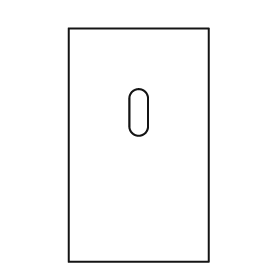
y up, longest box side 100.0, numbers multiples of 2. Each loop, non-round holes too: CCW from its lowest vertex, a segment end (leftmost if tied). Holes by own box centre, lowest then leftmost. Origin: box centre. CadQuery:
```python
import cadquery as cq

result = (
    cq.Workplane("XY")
    .moveTo(-30.0, -50.0)
    .lineTo(30.0, -50.0)
    .lineTo(30.0, 50.0)
    .lineTo(-30.0, 50.0)
    .close()
    .moveTo(-4.0, 8.0)
    .threePointArc((0.0, 4.0), (4.0, 8.0))
    .lineTo(4.0, 20.0)
    .threePointArc((0.0, 24.0), (-4.0, 20.0))
    .close()
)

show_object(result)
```